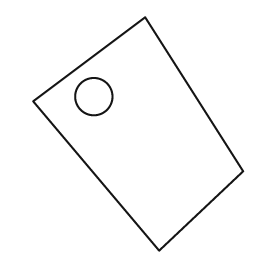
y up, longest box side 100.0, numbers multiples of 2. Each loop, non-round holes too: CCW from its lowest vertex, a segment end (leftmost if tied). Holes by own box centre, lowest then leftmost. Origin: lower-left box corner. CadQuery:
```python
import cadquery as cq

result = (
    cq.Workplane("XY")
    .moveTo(54.0, 0.0)
    .lineTo(90.0, 34.0)
    .lineTo(48.0, 100.0)
    .lineTo(0.0, 64.0)
    .close()
    .moveTo(26.0, 66.0)
    .circle(8.0)
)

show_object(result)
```